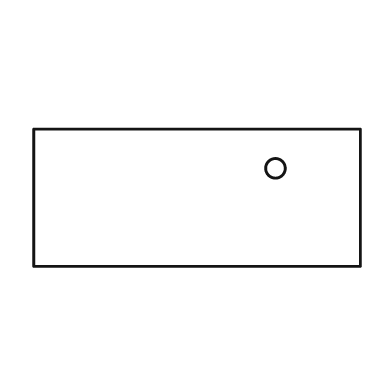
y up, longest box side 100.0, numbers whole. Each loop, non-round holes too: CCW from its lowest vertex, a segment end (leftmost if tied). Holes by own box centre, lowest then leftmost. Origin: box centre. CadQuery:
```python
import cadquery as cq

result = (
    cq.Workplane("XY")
    .moveTo(-50.0, -21.0)
    .lineTo(50.0, -21.0)
    .lineTo(50.0, 21.0)
    .lineTo(-50.0, 21.0)
    .close()
    .moveTo(24.0, 9.0)
    .circle(3.0)
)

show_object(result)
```